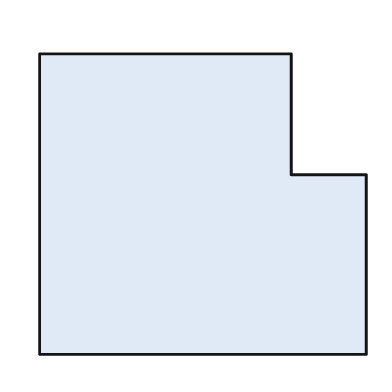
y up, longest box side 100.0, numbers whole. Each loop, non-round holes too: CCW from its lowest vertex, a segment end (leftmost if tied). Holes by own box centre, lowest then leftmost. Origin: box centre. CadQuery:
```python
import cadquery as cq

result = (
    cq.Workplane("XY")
    .moveTo(-50.0, -46.0)
    .lineTo(50.0, -46.0)
    .lineTo(50.0, 9.0)
    .lineTo(27.0, 9.0)
    .lineTo(27.0, 46.0)
    .lineTo(-50.0, 46.0)
    .close()
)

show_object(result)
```